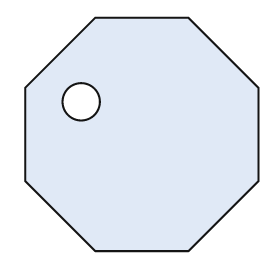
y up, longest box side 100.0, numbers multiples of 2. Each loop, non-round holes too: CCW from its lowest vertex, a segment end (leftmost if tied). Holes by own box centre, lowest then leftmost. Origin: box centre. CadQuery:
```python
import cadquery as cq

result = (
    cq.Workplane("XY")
    .moveTo(-20.0, -50.0)
    .lineTo(20.0, -50.0)
    .lineTo(50.0, -20.0)
    .lineTo(50.0, 20.0)
    .lineTo(20.0, 50.0)
    .lineTo(-20.0, 50.0)
    .lineTo(-50.0, 20.0)
    .lineTo(-50.0, -20.0)
    .close()
    .moveTo(-26.0, 14.0)
    .circle(8.0)
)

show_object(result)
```